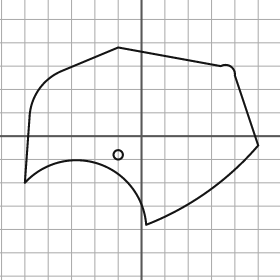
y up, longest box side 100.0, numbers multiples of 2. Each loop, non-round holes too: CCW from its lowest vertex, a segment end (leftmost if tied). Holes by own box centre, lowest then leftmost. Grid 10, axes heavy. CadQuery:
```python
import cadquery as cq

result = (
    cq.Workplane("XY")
    .moveTo(2.0, -38.0)
    .threePointArc((28.0, -24.0), (50.0, -4.0))
    .lineTo(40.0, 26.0)
    .threePointArc((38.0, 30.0), (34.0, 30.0))
    .lineTo(-10.0, 38.0)
    .lineTo(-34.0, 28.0)
    .threePointArc((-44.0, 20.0), (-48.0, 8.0))
    .lineTo(-50.0, -20.0)
    .threePointArc((-18.0, -12.0), (2.0, -38.0))
    .close()
    .moveTo(-10.0, -8.0)
    .circle(2.0)
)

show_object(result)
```